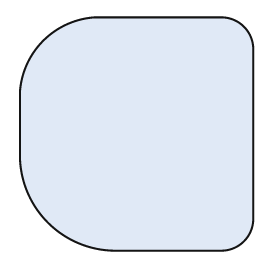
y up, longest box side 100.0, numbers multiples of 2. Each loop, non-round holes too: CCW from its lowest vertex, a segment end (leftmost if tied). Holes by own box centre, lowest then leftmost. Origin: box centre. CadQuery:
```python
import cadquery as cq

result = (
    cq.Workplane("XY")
    .moveTo(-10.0, -50.0)
    .lineTo(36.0, -50.0)
    .threePointArc((46.0, -46.0), (50.0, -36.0))
    .lineTo(50.0, 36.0)
    .threePointArc((46.0, 46.0), (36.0, 50.0))
    .lineTo(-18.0, 50.0)
    .threePointArc((-40.0, 40.0), (-50.0, 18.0))
    .lineTo(-50.0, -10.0)
    .threePointArc((-38.0, -38.0), (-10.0, -50.0))
    .close()
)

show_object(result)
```